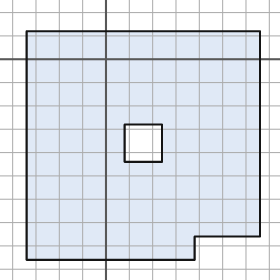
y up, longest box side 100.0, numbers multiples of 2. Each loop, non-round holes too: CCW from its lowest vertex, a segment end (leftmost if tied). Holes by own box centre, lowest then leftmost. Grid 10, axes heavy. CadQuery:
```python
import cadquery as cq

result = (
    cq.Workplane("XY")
    .moveTo(-34.0, -86.0)
    .lineTo(38.0, -86.0)
    .lineTo(38.0, -76.0)
    .lineTo(66.0, -76.0)
    .lineTo(66.0, 12.0)
    .lineTo(-34.0, 12.0)
    .close()
    .moveTo(8.0, -44.0)
    .lineTo(24.0, -44.0)
    .lineTo(24.0, -28.0)
    .lineTo(8.0, -28.0)
    .close()
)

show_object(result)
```